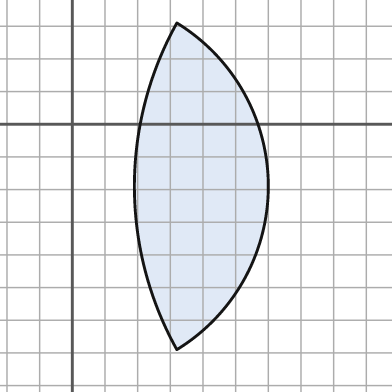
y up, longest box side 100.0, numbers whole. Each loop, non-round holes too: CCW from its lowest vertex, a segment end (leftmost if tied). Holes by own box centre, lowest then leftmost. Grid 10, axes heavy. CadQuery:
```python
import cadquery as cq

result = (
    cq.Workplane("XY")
    .moveTo(32.0, -69.0)
    .threePointArc((60.0, -19.0), (32.0, 31.0))
    .threePointArc((19.0, -19.0), (32.0, -69.0))
    .close()
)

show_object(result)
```